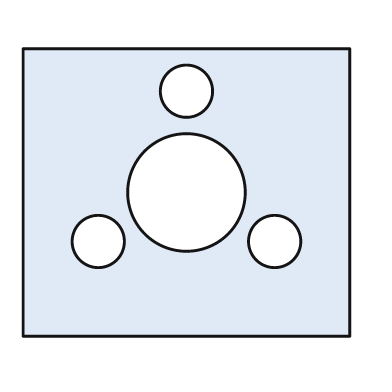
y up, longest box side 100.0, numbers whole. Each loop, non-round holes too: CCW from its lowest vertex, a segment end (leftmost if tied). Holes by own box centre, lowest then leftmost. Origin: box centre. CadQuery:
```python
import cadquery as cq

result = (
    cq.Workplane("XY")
    .moveTo(-50.0, -44.0)
    .lineTo(50.0, -44.0)
    .lineTo(50.0, 44.0)
    .lineTo(-50.0, 44.0)
    .close()
    .moveTo(-27.0, -15.0)
    .circle(8.0)
    .moveTo(27.0, -15.0)
    .circle(8.0)
    .moveTo(0.0, 0.0)
    .circle(18.0)
    .moveTo(0.0, 31.0)
    .circle(8.0)
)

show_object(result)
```